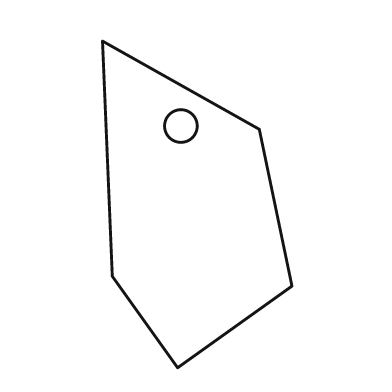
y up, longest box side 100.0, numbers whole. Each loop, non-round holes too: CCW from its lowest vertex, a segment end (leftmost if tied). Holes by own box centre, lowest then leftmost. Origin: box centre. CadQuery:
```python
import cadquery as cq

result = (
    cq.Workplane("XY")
    .moveTo(-6.0, -50.0)
    .lineTo(29.0, -25.0)
    .lineTo(19.0, 23.0)
    .lineTo(-29.0, 50.0)
    .lineTo(-26.0, -22.0)
    .close()
    .moveTo(-5.0, 24.0)
    .circle(5.0)
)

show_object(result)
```